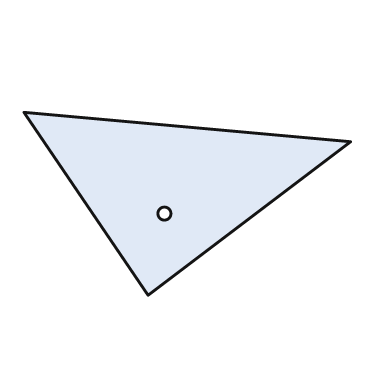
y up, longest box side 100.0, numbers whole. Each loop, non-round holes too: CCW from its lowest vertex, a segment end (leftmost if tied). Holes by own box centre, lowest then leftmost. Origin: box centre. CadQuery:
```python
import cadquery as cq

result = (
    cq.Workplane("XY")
    .moveTo(-12.0, -28.0)
    .lineTo(50.0, 19.0)
    .lineTo(-50.0, 28.0)
    .close()
    .moveTo(-7.0, -3.0)
    .circle(2.0)
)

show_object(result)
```